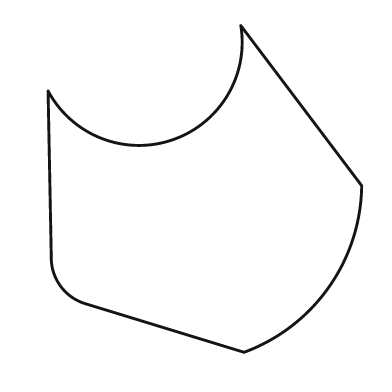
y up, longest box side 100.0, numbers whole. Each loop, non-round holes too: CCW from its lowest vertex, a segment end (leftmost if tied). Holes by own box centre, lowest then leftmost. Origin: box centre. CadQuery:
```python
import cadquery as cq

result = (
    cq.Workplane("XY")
    .moveTo(12.0, -50.0)
    .threePointArc((38.0, -30.0), (48.0, 1.0))
    .lineTo(11.0, 50.0)
    .threePointArc((-10.0, 15.0), (-48.0, 30.0))
    .lineTo(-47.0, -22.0)
    .threePointArc((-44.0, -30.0), (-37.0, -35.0))
    .close()
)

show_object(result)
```